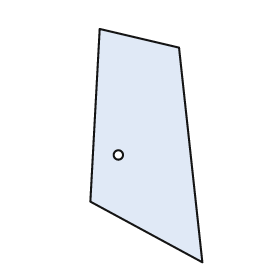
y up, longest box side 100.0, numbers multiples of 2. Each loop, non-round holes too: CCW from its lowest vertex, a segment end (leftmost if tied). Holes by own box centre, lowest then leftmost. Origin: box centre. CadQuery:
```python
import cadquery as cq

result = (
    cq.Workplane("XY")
    .moveTo(24.0, -50.0)
    .lineTo(14.0, 42.0)
    .lineTo(-20.0, 50.0)
    .lineTo(-24.0, -24.0)
    .close()
    .moveTo(-12.0, -4.0)
    .circle(2.0)
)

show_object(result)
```